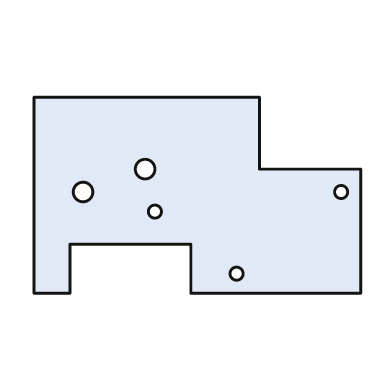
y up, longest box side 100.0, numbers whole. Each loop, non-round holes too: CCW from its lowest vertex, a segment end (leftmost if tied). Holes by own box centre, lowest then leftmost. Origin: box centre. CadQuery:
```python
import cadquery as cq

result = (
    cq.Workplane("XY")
    .moveTo(-50.0, -30.0)
    .lineTo(-39.0, -30.0)
    .lineTo(-39.0, -15.0)
    .lineTo(-2.0, -15.0)
    .lineTo(-2.0, -30.0)
    .lineTo(50.0, -30.0)
    .lineTo(50.0, 8.0)
    .lineTo(19.0, 8.0)
    .lineTo(19.0, 30.0)
    .lineTo(-50.0, 30.0)
    .close()
    .moveTo(12.0, -24.0)
    .circle(2.0)
    .moveTo(-13.0, -5.0)
    .circle(2.0)
    .moveTo(-35.0, 1.0)
    .circle(3.0)
    .moveTo(44.0, 1.0)
    .circle(2.0)
    .moveTo(-16.0, 8.0)
    .circle(3.0)
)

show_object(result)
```